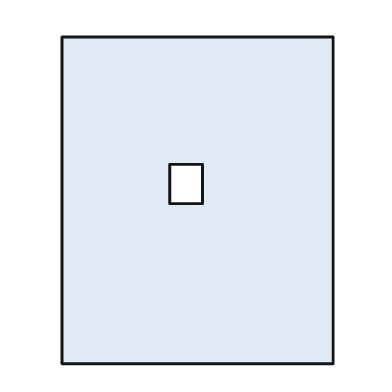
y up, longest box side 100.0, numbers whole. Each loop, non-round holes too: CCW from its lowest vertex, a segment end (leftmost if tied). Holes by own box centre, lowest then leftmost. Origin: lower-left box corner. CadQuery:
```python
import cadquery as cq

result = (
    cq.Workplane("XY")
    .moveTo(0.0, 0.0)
    .lineTo(83.0, 0.0)
    .lineTo(83.0, 100.0)
    .lineTo(0.0, 100.0)
    .close()
    .moveTo(33.0, 49.0)
    .lineTo(43.0, 49.0)
    .lineTo(43.0, 61.0)
    .lineTo(33.0, 61.0)
    .close()
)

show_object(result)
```